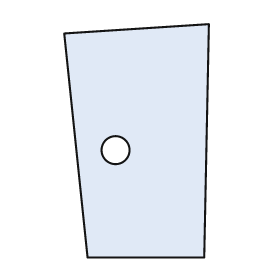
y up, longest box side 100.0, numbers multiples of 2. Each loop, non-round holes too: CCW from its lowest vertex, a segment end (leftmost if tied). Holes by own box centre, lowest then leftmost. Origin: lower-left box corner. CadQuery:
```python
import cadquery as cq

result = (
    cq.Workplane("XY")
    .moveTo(10.0, 0.0)
    .lineTo(60.0, 0.0)
    .lineTo(62.0, 100.0)
    .lineTo(0.0, 96.0)
    .close()
    .moveTo(22.0, 46.0)
    .circle(6.0)
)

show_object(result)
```